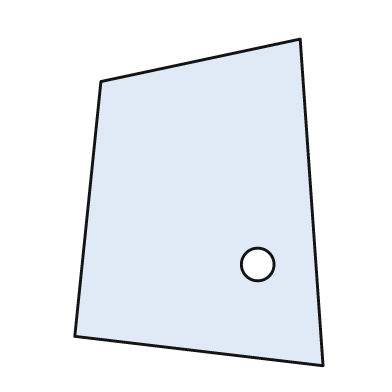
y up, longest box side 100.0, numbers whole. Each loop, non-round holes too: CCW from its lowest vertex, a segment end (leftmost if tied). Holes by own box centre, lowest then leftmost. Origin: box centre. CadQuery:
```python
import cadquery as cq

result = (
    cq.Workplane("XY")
    .moveTo(38.0, -50.0)
    .lineTo(31.0, 50.0)
    .lineTo(-30.0, 37.0)
    .lineTo(-38.0, -41.0)
    .close()
    .moveTo(18.0, -19.0)
    .circle(5.0)
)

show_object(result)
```